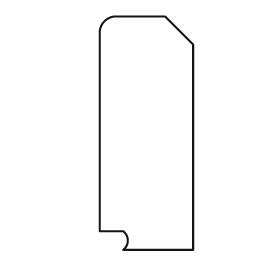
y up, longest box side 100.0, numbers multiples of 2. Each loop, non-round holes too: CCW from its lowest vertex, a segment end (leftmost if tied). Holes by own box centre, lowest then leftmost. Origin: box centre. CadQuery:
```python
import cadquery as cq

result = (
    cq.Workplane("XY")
    .moveTo(-10.0, -50.0)
    .lineTo(20.0, -50.0)
    .lineTo(20.0, 38.0)
    .lineTo(8.0, 50.0)
    .lineTo(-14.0, 50.0)
    .threePointArc((-18.0, 48.0), (-20.0, 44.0))
    .lineTo(-20.0, -42.0)
    .lineTo(-10.0, -42.0)
    .threePointArc((-8.0, -46.0), (-10.0, -50.0))
    .close()
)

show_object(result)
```